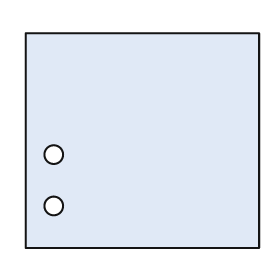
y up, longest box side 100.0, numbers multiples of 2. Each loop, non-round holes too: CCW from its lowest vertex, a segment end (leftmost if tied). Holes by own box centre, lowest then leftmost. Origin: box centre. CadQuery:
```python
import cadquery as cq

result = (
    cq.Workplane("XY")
    .moveTo(-50.0, -46.0)
    .lineTo(50.0, -46.0)
    .lineTo(50.0, 46.0)
    .lineTo(-50.0, 46.0)
    .close()
    .moveTo(-38.0, -28.0)
    .circle(4.0)
    .moveTo(-38.0, -6.0)
    .circle(4.0)
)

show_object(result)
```